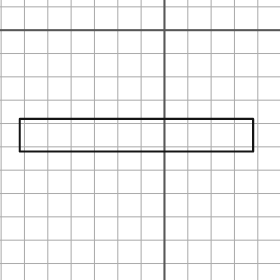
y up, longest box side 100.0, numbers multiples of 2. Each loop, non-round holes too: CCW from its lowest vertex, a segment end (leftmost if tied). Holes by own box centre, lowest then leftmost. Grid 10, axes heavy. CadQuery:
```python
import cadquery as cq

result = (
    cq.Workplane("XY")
    .moveTo(-62.0, -52.0)
    .lineTo(38.0, -52.0)
    .lineTo(38.0, -38.0)
    .lineTo(-62.0, -38.0)
    .close()
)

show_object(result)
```